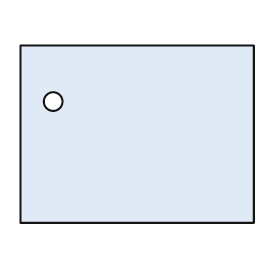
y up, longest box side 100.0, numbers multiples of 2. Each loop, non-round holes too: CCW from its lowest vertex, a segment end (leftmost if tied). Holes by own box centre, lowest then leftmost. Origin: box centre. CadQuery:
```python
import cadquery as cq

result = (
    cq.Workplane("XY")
    .moveTo(-50.0, -38.0)
    .lineTo(50.0, -38.0)
    .lineTo(50.0, 38.0)
    .lineTo(-50.0, 38.0)
    .close()
    .moveTo(-36.0, 14.0)
    .circle(4.0)
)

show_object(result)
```